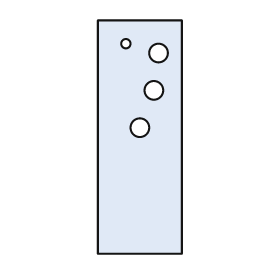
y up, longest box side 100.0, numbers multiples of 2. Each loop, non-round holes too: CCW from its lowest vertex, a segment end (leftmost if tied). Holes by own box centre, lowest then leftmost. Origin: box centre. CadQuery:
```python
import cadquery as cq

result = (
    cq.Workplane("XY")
    .moveTo(-18.0, -50.0)
    .lineTo(18.0, -50.0)
    .lineTo(18.0, 50.0)
    .lineTo(-18.0, 50.0)
    .close()
    .moveTo(0.0, 4.0)
    .circle(4.0)
    .moveTo(6.0, 20.0)
    .circle(4.0)
    .moveTo(8.0, 36.0)
    .circle(4.0)
    .moveTo(-6.0, 40.0)
    .circle(2.0)
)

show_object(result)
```